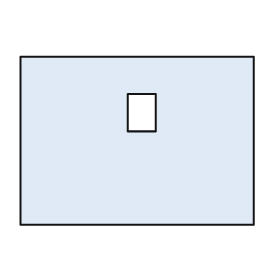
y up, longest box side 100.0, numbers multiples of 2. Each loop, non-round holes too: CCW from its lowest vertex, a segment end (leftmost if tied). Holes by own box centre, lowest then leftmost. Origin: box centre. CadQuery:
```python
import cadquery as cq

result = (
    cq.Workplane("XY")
    .moveTo(-50.0, -36.0)
    .lineTo(50.0, -36.0)
    .lineTo(50.0, 36.0)
    .lineTo(-50.0, 36.0)
    .close()
    .moveTo(-4.0, 4.0)
    .lineTo(8.0, 4.0)
    .lineTo(8.0, 20.0)
    .lineTo(-4.0, 20.0)
    .close()
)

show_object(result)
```